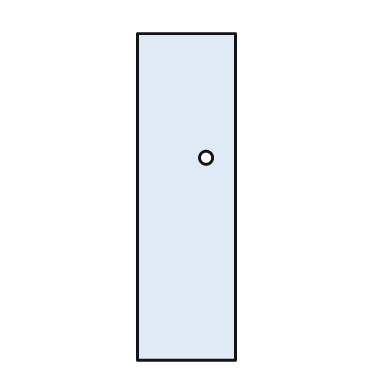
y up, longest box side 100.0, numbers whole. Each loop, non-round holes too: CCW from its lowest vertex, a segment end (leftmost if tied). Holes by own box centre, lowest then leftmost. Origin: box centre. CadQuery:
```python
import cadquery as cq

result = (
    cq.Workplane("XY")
    .moveTo(-15.0, -50.0)
    .lineTo(15.0, -50.0)
    .lineTo(15.0, 50.0)
    .lineTo(-15.0, 50.0)
    .close()
    .moveTo(6.0, 12.0)
    .circle(2.0)
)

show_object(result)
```